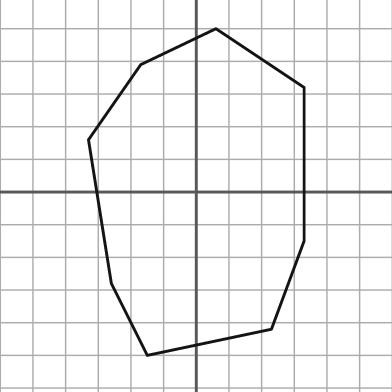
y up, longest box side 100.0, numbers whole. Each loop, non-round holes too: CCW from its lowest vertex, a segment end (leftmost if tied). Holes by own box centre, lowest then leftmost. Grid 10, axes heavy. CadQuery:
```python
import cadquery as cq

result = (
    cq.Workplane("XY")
    .moveTo(-15.0, -50.0)
    .lineTo(23.0, -42.0)
    .lineTo(33.0, -15.0)
    .lineTo(33.0, 32.0)
    .lineTo(6.0, 50.0)
    .lineTo(-17.0, 39.0)
    .lineTo(-33.0, 16.0)
    .lineTo(-26.0, -28.0)
    .close()
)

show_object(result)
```